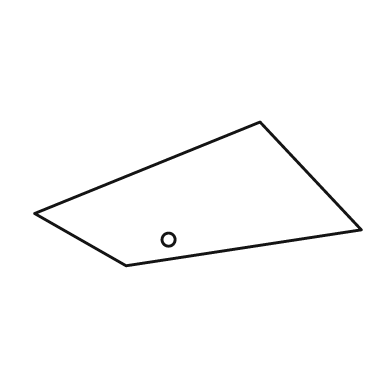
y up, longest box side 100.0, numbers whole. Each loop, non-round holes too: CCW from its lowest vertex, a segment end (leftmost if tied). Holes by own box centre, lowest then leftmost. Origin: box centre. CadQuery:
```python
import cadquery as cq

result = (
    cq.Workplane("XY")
    .moveTo(-22.0, -22.0)
    .lineTo(50.0, -11.0)
    .lineTo(19.0, 22.0)
    .lineTo(-50.0, -6.0)
    .close()
    .moveTo(-9.0, -14.0)
    .circle(2.0)
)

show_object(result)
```